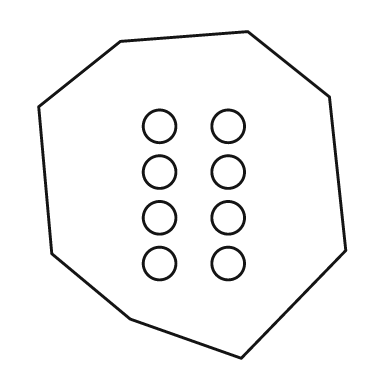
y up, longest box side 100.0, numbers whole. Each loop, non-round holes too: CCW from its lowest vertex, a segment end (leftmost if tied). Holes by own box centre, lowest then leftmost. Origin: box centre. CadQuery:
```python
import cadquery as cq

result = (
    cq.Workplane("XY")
    .moveTo(15.0, -50.0)
    .lineTo(47.0, -17.0)
    .lineTo(42.0, 30.0)
    .lineTo(17.0, 50.0)
    .lineTo(-22.0, 47.0)
    .lineTo(-47.0, 27.0)
    .lineTo(-43.0, -18.0)
    .lineTo(-19.0, -38.0)
    .close()
    .moveTo(-10.0, -21.0)
    .circle(5.0)
    .moveTo(11.0, -21.0)
    .circle(5.0)
    .moveTo(-10.0, -7.0)
    .circle(5.0)
    .moveTo(11.0, -7.0)
    .circle(5.0)
    .moveTo(-10.0, 7.0)
    .circle(5.0)
    .moveTo(11.0, 7.0)
    .circle(5.0)
    .moveTo(-10.0, 21.0)
    .circle(5.0)
    .moveTo(11.0, 21.0)
    .circle(5.0)
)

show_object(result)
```